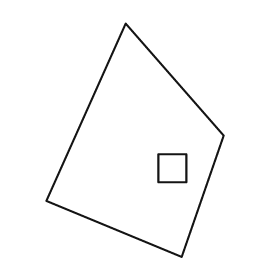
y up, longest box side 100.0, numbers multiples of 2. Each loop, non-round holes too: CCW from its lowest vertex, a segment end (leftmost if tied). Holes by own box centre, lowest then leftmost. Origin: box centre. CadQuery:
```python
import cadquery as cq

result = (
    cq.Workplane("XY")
    .moveTo(20.0, -50.0)
    .lineTo(38.0, 2.0)
    .lineTo(-4.0, 50.0)
    .lineTo(-38.0, -26.0)
    .close()
    .moveTo(10.0, -18.0)
    .lineTo(22.0, -18.0)
    .lineTo(22.0, -6.0)
    .lineTo(10.0, -6.0)
    .close()
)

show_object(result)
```